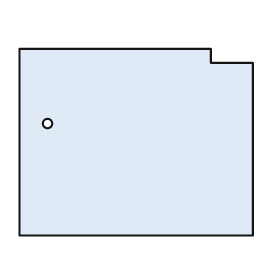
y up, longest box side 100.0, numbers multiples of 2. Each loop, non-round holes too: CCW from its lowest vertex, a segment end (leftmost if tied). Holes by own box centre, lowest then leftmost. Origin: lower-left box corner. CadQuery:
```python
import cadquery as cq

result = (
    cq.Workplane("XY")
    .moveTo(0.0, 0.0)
    .lineTo(100.0, 0.0)
    .lineTo(100.0, 74.0)
    .lineTo(82.0, 74.0)
    .lineTo(82.0, 80.0)
    .lineTo(0.0, 80.0)
    .close()
    .moveTo(12.0, 48.0)
    .circle(2.0)
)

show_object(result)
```